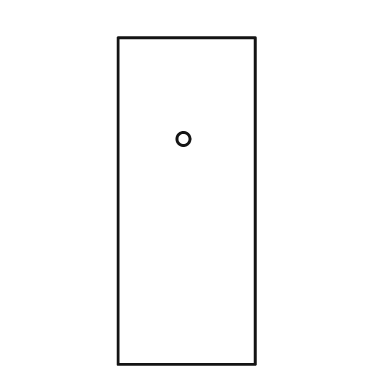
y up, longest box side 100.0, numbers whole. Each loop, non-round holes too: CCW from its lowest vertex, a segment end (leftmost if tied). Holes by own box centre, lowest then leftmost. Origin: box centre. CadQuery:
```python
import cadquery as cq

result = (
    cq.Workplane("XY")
    .moveTo(-21.0, -50.0)
    .lineTo(21.0, -50.0)
    .lineTo(21.0, 50.0)
    .lineTo(-21.0, 50.0)
    .close()
    .moveTo(-1.0, 19.0)
    .circle(2.0)
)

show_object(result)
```